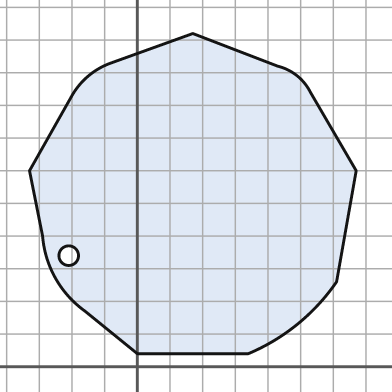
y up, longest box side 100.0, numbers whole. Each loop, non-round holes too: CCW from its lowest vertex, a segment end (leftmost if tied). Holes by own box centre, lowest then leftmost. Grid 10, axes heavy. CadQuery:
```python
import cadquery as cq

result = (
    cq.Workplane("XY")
    .moveTo(0.0, 4.0)
    .lineTo(34.0, 4.0)
    .threePointArc((49.0, 13.0), (61.0, 26.0))
    .lineTo(67.0, 60.0)
    .lineTo(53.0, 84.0)
    .threePointArc((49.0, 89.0), (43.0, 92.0))
    .lineTo(17.0, 102.0)
    .lineTo(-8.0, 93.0)
    .threePointArc((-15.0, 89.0), (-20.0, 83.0))
    .lineTo(-33.0, 60.0)
    .lineTo(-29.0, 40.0)
    .threePointArc((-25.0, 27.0), (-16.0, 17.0))
    .close()
    .moveTo(-21.0, 34.0)
    .circle(3.0)
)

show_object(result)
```